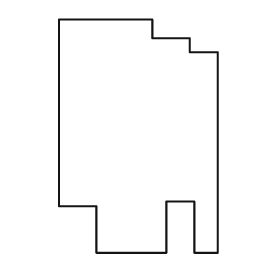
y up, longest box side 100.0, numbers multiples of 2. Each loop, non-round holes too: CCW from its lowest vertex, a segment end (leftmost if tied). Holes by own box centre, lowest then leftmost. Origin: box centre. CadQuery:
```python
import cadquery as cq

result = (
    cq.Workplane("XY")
    .moveTo(-18.0, -50.0)
    .lineTo(12.0, -50.0)
    .lineTo(12.0, -28.0)
    .lineTo(24.0, -28.0)
    .lineTo(24.0, -50.0)
    .lineTo(34.0, -50.0)
    .lineTo(34.0, 36.0)
    .lineTo(22.0, 36.0)
    .lineTo(22.0, 42.0)
    .lineTo(6.0, 42.0)
    .lineTo(6.0, 50.0)
    .lineTo(-34.0, 50.0)
    .lineTo(-34.0, -30.0)
    .lineTo(-18.0, -30.0)
    .close()
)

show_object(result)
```